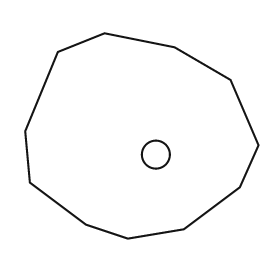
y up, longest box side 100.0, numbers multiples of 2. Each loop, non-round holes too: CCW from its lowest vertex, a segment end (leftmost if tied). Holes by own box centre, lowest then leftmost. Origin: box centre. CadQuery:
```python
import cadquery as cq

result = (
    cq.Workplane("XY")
    .moveTo(-6.0, -44.0)
    .lineTo(18.0, -40.0)
    .lineTo(42.0, -22.0)
    .lineTo(50.0, -4.0)
    .lineTo(38.0, 24.0)
    .lineTo(14.0, 38.0)
    .lineTo(-16.0, 44.0)
    .lineTo(-36.0, 36.0)
    .lineTo(-50.0, 2.0)
    .lineTo(-48.0, -20.0)
    .lineTo(-24.0, -38.0)
    .close()
    .moveTo(6.0, -8.0)
    .circle(6.0)
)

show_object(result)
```